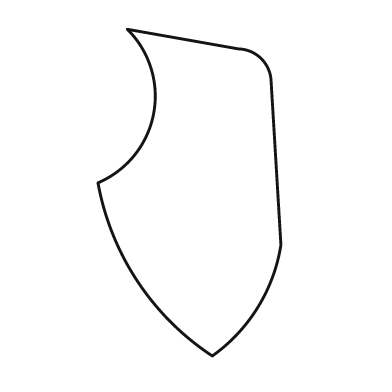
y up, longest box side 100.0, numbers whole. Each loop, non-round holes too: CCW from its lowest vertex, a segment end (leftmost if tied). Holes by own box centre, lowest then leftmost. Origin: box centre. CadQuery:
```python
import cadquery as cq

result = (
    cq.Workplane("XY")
    .moveTo(7.0, -50.0)
    .threePointArc((21.0, -35.0), (28.0, -16.0))
    .lineTo(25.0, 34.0)
    .threePointArc((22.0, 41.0), (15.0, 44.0))
    .lineTo(-19.0, 50.0)
    .threePointArc((-11.0, 24.0), (-28.0, 3.0))
    .threePointArc((-16.0, -27.0), (7.0, -50.0))
    .close()
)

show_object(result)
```